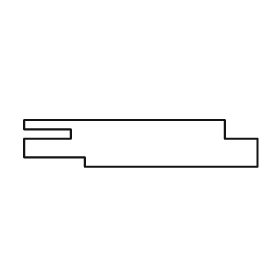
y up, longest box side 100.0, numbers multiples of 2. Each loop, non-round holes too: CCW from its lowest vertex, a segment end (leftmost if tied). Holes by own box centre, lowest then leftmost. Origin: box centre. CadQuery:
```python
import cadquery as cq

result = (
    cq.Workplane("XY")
    .moveTo(-24.0, -10.0)
    .lineTo(50.0, -10.0)
    .lineTo(50.0, 2.0)
    .lineTo(36.0, 2.0)
    .lineTo(36.0, 10.0)
    .lineTo(-50.0, 10.0)
    .lineTo(-50.0, 6.0)
    .lineTo(-30.0, 6.0)
    .lineTo(-30.0, 2.0)
    .lineTo(-50.0, 2.0)
    .lineTo(-50.0, -6.0)
    .lineTo(-24.0, -6.0)
    .close()
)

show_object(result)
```